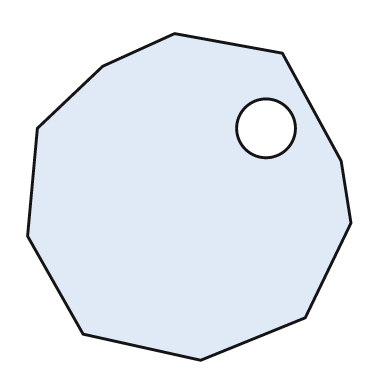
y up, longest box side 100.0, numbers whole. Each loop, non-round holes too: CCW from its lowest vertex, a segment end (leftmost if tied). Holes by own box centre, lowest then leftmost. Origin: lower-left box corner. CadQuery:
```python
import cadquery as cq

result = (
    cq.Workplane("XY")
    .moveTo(53.0, 0.0)
    .lineTo(85.0, 13.0)
    .lineTo(99.0, 42.0)
    .lineTo(96.0, 61.0)
    .lineTo(78.0, 94.0)
    .lineTo(45.0, 100.0)
    .lineTo(23.0, 90.0)
    .lineTo(3.0, 71.0)
    .lineTo(0.0, 38.0)
    .lineTo(17.0, 8.0)
    .close()
    .moveTo(73.0, 71.0)
    .circle(9.0)
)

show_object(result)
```